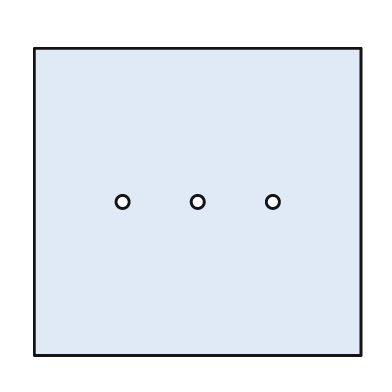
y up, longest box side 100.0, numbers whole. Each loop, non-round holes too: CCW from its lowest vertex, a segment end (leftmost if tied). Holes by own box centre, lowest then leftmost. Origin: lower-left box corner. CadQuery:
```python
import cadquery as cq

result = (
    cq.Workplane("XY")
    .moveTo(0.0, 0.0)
    .lineTo(100.0, 0.0)
    .lineTo(100.0, 94.0)
    .lineTo(0.0, 94.0)
    .close()
    .moveTo(27.0, 47.0)
    .circle(2.0)
    .moveTo(50.0, 47.0)
    .circle(2.0)
    .moveTo(73.0, 47.0)
    .circle(2.0)
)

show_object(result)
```